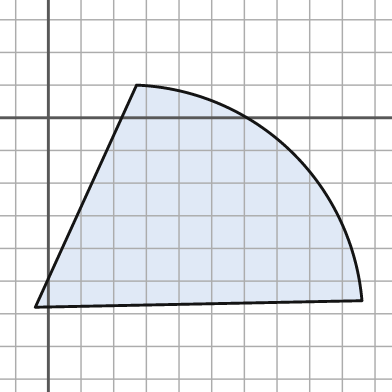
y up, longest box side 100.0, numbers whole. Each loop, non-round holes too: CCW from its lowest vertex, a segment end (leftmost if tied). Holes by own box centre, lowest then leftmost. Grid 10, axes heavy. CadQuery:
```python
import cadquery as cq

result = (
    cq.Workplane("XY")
    .moveTo(-4.0, -58.0)
    .lineTo(96.0, -56.0)
    .threePointArc((74.0, -10.0), (27.0, 10.0))
    .close()
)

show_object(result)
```